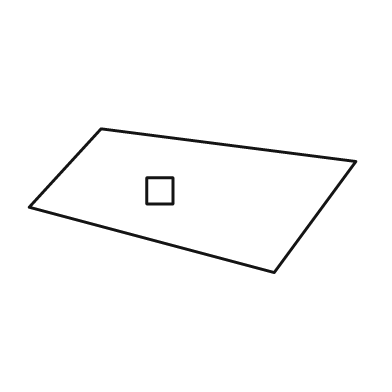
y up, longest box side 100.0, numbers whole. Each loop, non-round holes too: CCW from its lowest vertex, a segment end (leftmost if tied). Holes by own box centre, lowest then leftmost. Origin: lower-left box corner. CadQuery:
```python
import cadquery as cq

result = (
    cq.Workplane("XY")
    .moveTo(75.0, 0.0)
    .lineTo(100.0, 34.0)
    .lineTo(22.0, 44.0)
    .lineTo(0.0, 20.0)
    .close()
    .moveTo(36.0, 21.0)
    .lineTo(44.0, 21.0)
    .lineTo(44.0, 29.0)
    .lineTo(36.0, 29.0)
    .close()
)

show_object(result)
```